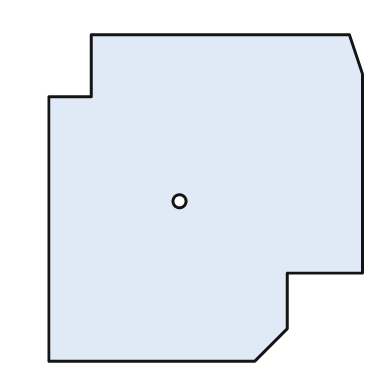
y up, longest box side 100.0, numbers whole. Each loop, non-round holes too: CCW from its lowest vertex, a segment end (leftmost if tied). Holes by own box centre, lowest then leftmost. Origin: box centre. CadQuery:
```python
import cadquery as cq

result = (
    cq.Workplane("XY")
    .moveTo(-48.0, -50.0)
    .lineTo(15.0, -50.0)
    .lineTo(25.0, -40.0)
    .lineTo(25.0, -23.0)
    .lineTo(48.0, -23.0)
    .lineTo(48.0, 38.0)
    .lineTo(44.0, 50.0)
    .lineTo(-35.0, 50.0)
    .lineTo(-35.0, 31.0)
    .lineTo(-48.0, 31.0)
    .close()
    .moveTo(-8.0, -1.0)
    .circle(2.0)
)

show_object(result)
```